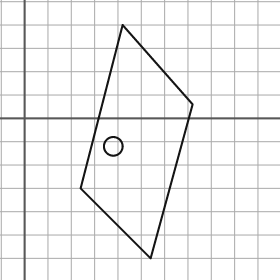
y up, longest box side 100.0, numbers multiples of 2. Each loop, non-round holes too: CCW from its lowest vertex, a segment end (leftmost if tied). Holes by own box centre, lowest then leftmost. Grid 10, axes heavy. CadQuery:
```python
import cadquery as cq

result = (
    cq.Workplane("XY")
    .moveTo(54.0, -60.0)
    .lineTo(72.0, 6.0)
    .lineTo(42.0, 40.0)
    .lineTo(24.0, -30.0)
    .close()
    .moveTo(38.0, -12.0)
    .circle(4.0)
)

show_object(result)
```